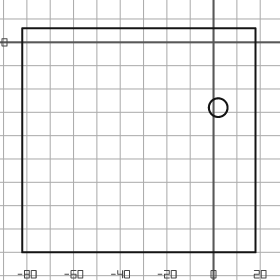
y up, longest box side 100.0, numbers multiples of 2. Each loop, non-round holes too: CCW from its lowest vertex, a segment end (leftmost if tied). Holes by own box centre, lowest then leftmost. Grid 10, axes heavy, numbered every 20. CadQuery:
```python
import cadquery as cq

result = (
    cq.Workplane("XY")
    .moveTo(-82.0, -90.0)
    .lineTo(18.0, -90.0)
    .lineTo(18.0, 6.0)
    .lineTo(-82.0, 6.0)
    .close()
    .moveTo(2.0, -28.0)
    .circle(4.0)
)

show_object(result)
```